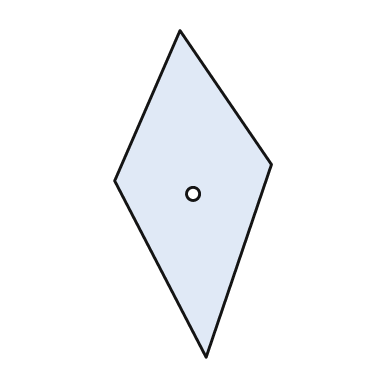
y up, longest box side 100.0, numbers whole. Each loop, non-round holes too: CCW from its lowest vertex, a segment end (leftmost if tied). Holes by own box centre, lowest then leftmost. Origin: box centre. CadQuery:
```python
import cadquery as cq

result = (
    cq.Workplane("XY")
    .moveTo(4.0, -50.0)
    .lineTo(24.0, 9.0)
    .lineTo(-4.0, 50.0)
    .lineTo(-24.0, 4.0)
    .close()
    .moveTo(0.0, 0.0)
    .circle(2.0)
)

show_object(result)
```